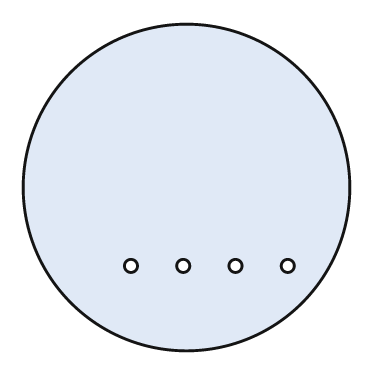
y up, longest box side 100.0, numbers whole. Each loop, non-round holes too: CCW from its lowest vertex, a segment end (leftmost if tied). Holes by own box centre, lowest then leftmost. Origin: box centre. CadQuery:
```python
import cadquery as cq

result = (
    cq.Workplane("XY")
    .moveTo(0.0, 0.0)
    .circle(50.0)
    .moveTo(-17.0, -24.0)
    .circle(2.0)
    .moveTo(-1.0, -24.0)
    .circle(2.0)
    .moveTo(15.0, -24.0)
    .circle(2.0)
    .moveTo(31.0, -24.0)
    .circle(2.0)
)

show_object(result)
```